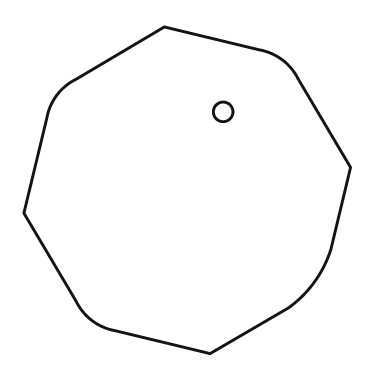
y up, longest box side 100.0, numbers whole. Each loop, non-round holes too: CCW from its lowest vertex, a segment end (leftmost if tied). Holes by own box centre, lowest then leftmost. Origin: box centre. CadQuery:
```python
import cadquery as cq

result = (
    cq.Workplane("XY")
    .moveTo(7.0, -50.0)
    .lineTo(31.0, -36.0)
    .threePointArc((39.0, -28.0), (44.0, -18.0))
    .lineTo(50.0, 7.0)
    .lineTo(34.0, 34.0)
    .threePointArc((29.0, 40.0), (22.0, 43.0))
    .lineTo(-7.0, 50.0)
    .lineTo(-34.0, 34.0)
    .threePointArc((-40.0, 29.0), (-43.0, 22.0))
    .lineTo(-50.0, -7.0)
    .lineTo(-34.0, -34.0)
    .threePointArc((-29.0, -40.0), (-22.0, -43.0))
    .close()
    .moveTo(11.0, 24.0)
    .circle(3.0)
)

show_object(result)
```